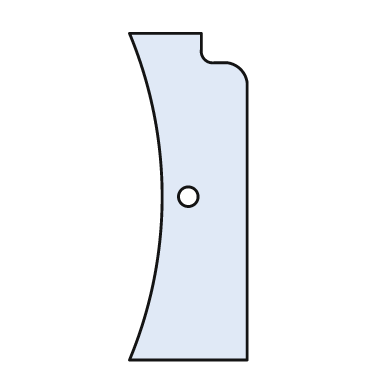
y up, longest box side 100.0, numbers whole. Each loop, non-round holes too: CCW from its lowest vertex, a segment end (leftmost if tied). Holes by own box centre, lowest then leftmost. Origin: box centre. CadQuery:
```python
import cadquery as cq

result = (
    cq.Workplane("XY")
    .moveTo(-18.0, -50.0)
    .lineTo(18.0, -50.0)
    .lineTo(18.0, 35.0)
    .threePointArc((16.0, 39.0), (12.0, 41.0))
    .lineTo(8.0, 41.0)
    .threePointArc((5.0, 42.0), (4.0, 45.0))
    .lineTo(4.0, 50.0)
    .lineTo(-18.0, 50.0)
    .threePointArc((-8.0, 0.0), (-18.0, -50.0))
    .close()
    .moveTo(0.0, 0.0)
    .circle(3.0)
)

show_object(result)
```